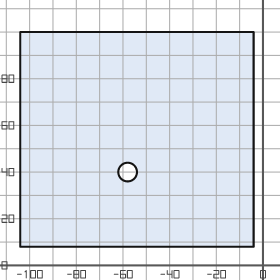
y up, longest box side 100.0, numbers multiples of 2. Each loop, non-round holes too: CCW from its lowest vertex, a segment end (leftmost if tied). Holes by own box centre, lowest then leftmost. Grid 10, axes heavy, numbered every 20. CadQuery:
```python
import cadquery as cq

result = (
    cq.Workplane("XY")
    .moveTo(-104.0, 8.0)
    .lineTo(-4.0, 8.0)
    .lineTo(-4.0, 100.0)
    .lineTo(-104.0, 100.0)
    .close()
    .moveTo(-58.0, 40.0)
    .circle(4.0)
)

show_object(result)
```